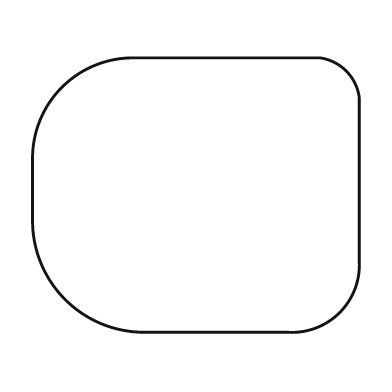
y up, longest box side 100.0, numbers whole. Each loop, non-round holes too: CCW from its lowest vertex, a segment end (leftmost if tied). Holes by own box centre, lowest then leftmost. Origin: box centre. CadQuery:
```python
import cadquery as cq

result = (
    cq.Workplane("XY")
    .moveTo(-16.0, -42.0)
    .lineTo(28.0, -42.0)
    .threePointArc((44.0, -36.0), (50.0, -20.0))
    .lineTo(50.0, 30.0)
    .threePointArc((46.0, 38.0), (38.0, 42.0))
    .lineTo(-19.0, 42.0)
    .threePointArc((-41.0, 33.0), (-50.0, 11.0))
    .lineTo(-50.0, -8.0)
    .threePointArc((-40.0, -32.0), (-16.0, -42.0))
    .close()
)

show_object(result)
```